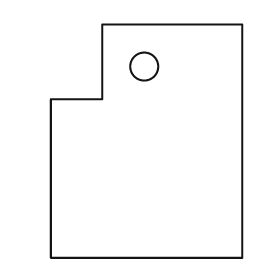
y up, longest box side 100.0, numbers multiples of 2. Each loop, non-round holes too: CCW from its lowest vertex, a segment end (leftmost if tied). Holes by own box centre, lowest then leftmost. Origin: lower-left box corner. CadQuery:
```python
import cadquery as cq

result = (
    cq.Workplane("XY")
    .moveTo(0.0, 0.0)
    .lineTo(82.0, 0.0)
    .lineTo(82.0, 100.0)
    .lineTo(22.0, 100.0)
    .lineTo(22.0, 68.0)
    .lineTo(0.0, 68.0)
    .close()
    .moveTo(40.0, 82.0)
    .circle(6.0)
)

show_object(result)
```